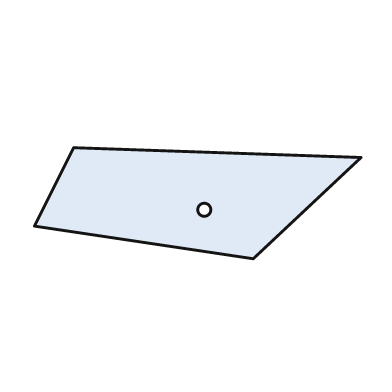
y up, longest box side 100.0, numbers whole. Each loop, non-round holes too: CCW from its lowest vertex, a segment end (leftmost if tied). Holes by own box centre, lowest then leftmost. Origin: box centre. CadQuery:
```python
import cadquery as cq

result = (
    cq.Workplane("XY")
    .moveTo(17.0, -17.0)
    .lineTo(50.0, 14.0)
    .lineTo(-38.0, 17.0)
    .lineTo(-50.0, -7.0)
    .close()
    .moveTo(2.0, -2.0)
    .circle(2.0)
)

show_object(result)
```